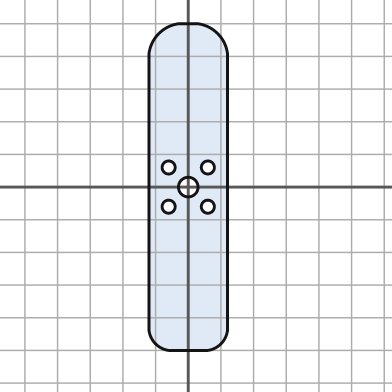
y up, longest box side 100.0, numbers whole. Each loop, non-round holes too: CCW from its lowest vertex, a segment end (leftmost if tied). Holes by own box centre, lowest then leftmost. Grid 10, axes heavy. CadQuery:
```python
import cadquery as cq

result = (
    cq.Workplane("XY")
    .moveTo(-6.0, -50.0)
    .lineTo(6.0, -50.0)
    .threePointArc((10.0, -48.0), (12.0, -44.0))
    .lineTo(12.0, 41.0)
    .threePointArc((9.0, 47.0), (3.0, 50.0))
    .lineTo(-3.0, 50.0)
    .threePointArc((-9.0, 47.0), (-12.0, 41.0))
    .lineTo(-12.0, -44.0)
    .threePointArc((-10.0, -48.0), (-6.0, -50.0))
    .close()
    .moveTo(-6.0, -6.0)
    .circle(2.0)
    .moveTo(6.0, -6.0)
    .circle(2.0)
    .moveTo(0.0, 0.0)
    .circle(3.0)
    .moveTo(-6.0, 6.0)
    .circle(2.0)
    .moveTo(6.0, 6.0)
    .circle(2.0)
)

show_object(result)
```